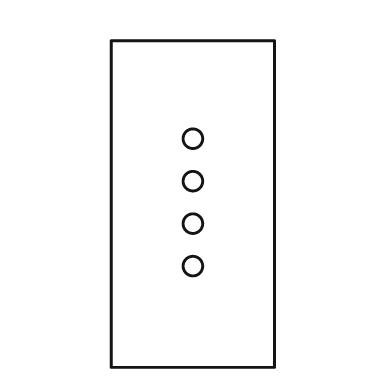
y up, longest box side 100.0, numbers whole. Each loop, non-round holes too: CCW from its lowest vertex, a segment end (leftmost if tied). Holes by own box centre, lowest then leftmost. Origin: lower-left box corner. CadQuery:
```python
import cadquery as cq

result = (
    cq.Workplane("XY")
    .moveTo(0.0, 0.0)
    .lineTo(50.0, 0.0)
    .lineTo(50.0, 100.0)
    .lineTo(0.0, 100.0)
    .close()
    .moveTo(25.0, 31.0)
    .circle(3.0)
    .moveTo(25.0, 44.0)
    .circle(3.0)
    .moveTo(25.0, 57.0)
    .circle(3.0)
    .moveTo(25.0, 70.0)
    .circle(3.0)
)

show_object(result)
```